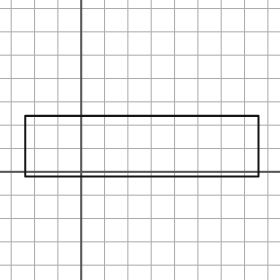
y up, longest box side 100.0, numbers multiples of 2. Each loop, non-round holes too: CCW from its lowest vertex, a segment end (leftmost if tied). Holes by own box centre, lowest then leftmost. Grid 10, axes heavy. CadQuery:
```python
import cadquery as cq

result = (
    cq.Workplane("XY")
    .moveTo(-24.0, -2.0)
    .lineTo(76.0, -2.0)
    .lineTo(76.0, 24.0)
    .lineTo(-24.0, 24.0)
    .close()
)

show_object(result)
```